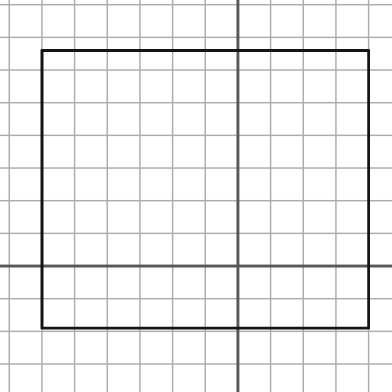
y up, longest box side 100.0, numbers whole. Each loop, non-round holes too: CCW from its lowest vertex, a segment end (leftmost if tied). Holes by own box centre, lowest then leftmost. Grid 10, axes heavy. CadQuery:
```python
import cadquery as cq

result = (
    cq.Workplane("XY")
    .moveTo(-60.0, -19.0)
    .lineTo(40.0, -19.0)
    .lineTo(40.0, 66.0)
    .lineTo(-60.0, 66.0)
    .close()
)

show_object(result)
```